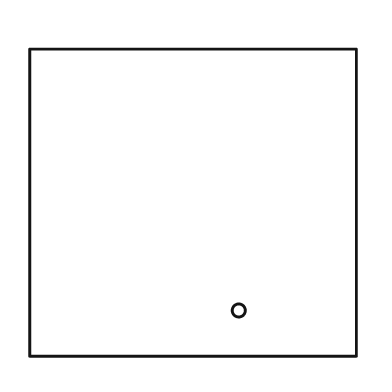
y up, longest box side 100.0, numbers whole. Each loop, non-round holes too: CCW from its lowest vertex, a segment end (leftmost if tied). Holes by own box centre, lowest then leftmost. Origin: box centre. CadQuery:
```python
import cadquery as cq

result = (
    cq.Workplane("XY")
    .moveTo(-50.0, -47.0)
    .lineTo(50.0, -47.0)
    .lineTo(50.0, 47.0)
    .lineTo(-50.0, 47.0)
    .close()
    .moveTo(14.0, -33.0)
    .circle(2.0)
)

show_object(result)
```